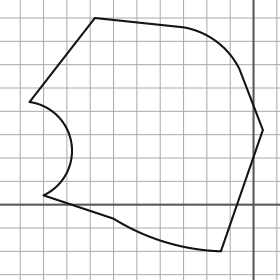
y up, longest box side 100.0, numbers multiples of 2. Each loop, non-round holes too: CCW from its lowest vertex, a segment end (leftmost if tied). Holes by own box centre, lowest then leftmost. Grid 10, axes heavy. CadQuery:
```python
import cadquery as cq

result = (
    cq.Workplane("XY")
    .moveTo(-14.0, -20.0)
    .lineTo(4.0, 32.0)
    .lineTo(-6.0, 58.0)
    .threePointArc((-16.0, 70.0), (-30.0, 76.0))
    .lineTo(-68.0, 80.0)
    .lineTo(-96.0, 44.0)
    .threePointArc((-78.0, 26.0), (-90.0, 4.0))
    .lineTo(-60.0, -6.0)
    .threePointArc((-38.0, -16.0), (-14.0, -20.0))
    .close()
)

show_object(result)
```